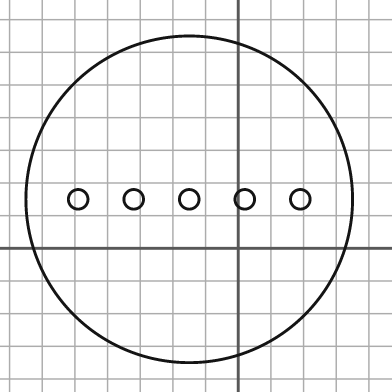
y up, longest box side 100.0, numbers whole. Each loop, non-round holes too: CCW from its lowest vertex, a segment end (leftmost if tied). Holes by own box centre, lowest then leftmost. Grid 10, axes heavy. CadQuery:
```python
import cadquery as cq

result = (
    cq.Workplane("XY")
    .moveTo(-15.0, 15.0)
    .circle(50.0)
    .moveTo(-49.0, 15.0)
    .circle(3.0)
    .moveTo(-32.0, 15.0)
    .circle(3.0)
    .moveTo(-15.0, 15.0)
    .circle(3.0)
    .moveTo(2.0, 15.0)
    .circle(3.0)
    .moveTo(19.0, 15.0)
    .circle(3.0)
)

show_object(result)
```